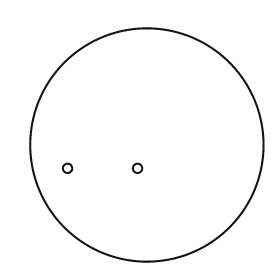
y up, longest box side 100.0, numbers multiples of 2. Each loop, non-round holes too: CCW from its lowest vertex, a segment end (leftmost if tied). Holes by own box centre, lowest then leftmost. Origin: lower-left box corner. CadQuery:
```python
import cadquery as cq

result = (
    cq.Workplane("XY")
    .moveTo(50.0, 50.0)
    .circle(50.0)
    .moveTo(16.0, 40.0)
    .circle(2.0)
    .moveTo(46.0, 40.0)
    .circle(2.0)
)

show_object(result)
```